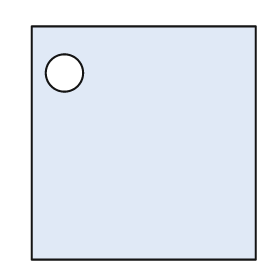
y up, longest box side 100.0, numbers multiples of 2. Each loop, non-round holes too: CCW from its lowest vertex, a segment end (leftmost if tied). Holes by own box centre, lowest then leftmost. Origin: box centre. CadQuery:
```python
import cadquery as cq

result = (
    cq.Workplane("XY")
    .moveTo(-48.0, -50.0)
    .lineTo(48.0, -50.0)
    .lineTo(48.0, 50.0)
    .lineTo(-48.0, 50.0)
    .close()
    .moveTo(-34.0, 30.0)
    .circle(8.0)
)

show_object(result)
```